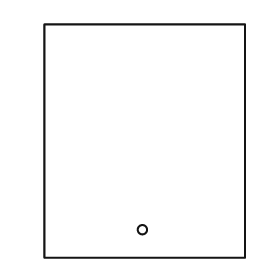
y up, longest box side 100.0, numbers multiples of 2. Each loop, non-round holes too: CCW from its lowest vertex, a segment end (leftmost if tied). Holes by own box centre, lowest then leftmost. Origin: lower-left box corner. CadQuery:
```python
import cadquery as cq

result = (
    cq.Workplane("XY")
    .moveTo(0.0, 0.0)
    .lineTo(86.0, 0.0)
    .lineTo(86.0, 100.0)
    .lineTo(0.0, 100.0)
    .close()
    .moveTo(42.0, 12.0)
    .circle(2.0)
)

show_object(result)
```